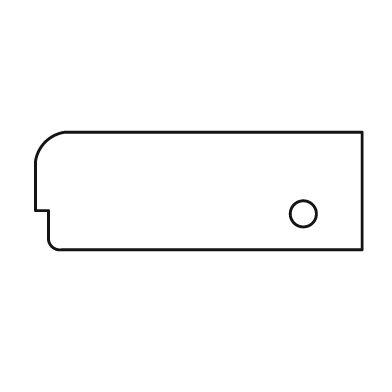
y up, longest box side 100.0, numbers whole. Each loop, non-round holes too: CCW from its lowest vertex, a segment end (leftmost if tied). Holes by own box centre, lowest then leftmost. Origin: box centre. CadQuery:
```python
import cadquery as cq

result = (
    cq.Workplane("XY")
    .moveTo(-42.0, -18.0)
    .lineTo(50.0, -18.0)
    .lineTo(50.0, 18.0)
    .lineTo(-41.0, 18.0)
    .threePointArc((-47.0, 15.0), (-50.0, 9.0))
    .lineTo(-50.0, -6.0)
    .lineTo(-46.0, -6.0)
    .lineTo(-46.0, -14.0)
    .threePointArc((-45.0, -17.0), (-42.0, -18.0))
    .close()
    .moveTo(32.0, -7.0)
    .circle(4.0)
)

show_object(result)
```